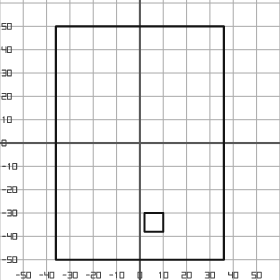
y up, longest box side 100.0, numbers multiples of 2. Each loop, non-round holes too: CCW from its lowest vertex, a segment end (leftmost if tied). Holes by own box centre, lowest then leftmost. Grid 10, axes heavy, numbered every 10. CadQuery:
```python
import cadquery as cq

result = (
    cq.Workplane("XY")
    .moveTo(-36.0, -50.0)
    .lineTo(36.0, -50.0)
    .lineTo(36.0, 50.0)
    .lineTo(-36.0, 50.0)
    .close()
    .moveTo(2.0, -38.0)
    .lineTo(10.0, -38.0)
    .lineTo(10.0, -30.0)
    .lineTo(2.0, -30.0)
    .close()
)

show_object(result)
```